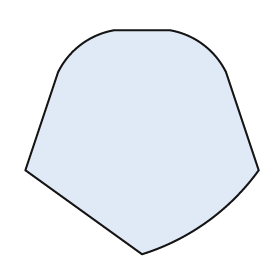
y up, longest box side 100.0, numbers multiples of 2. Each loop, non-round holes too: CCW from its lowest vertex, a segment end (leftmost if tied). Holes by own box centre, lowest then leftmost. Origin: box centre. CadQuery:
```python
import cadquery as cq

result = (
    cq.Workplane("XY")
    .moveTo(0.0, -48.0)
    .threePointArc((28.0, -34.0), (50.0, -12.0))
    .lineTo(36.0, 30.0)
    .threePointArc((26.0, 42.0), (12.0, 48.0))
    .lineTo(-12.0, 48.0)
    .threePointArc((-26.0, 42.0), (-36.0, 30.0))
    .lineTo(-50.0, -12.0)
    .close()
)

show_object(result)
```